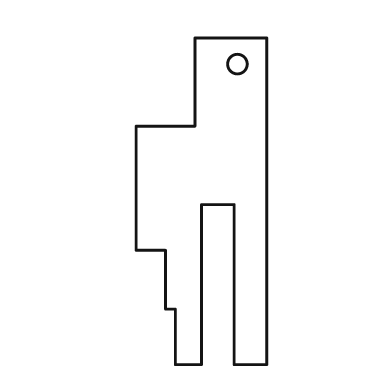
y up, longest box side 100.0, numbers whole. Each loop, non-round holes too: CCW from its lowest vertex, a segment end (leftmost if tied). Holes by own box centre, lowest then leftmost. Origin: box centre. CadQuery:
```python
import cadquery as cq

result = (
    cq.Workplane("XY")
    .moveTo(-8.0, -50.0)
    .lineTo(0.0, -50.0)
    .lineTo(0.0, -1.0)
    .lineTo(10.0, -1.0)
    .lineTo(10.0, -50.0)
    .lineTo(20.0, -50.0)
    .lineTo(20.0, 50.0)
    .lineTo(-2.0, 50.0)
    .lineTo(-2.0, 23.0)
    .lineTo(-20.0, 23.0)
    .lineTo(-20.0, -15.0)
    .lineTo(-11.0, -15.0)
    .lineTo(-11.0, -33.0)
    .lineTo(-8.0, -33.0)
    .close()
    .moveTo(11.0, 42.0)
    .circle(3.0)
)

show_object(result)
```